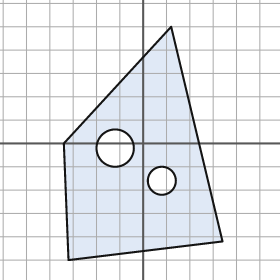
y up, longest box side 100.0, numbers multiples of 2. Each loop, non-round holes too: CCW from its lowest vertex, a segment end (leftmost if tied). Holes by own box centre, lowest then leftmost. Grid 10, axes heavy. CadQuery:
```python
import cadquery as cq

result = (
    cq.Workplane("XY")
    .moveTo(-32.0, -50.0)
    .lineTo(34.0, -42.0)
    .lineTo(12.0, 50.0)
    .lineTo(-34.0, 0.0)
    .close()
    .moveTo(8.0, -16.0)
    .circle(6.0)
    .moveTo(-12.0, -2.0)
    .circle(8.0)
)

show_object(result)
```